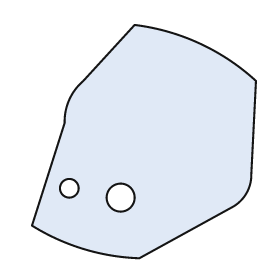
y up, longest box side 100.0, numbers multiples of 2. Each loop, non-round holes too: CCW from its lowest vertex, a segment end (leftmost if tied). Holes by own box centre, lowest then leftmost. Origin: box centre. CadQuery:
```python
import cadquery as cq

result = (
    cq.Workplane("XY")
    .moveTo(-2.0, -50.0)
    .lineTo(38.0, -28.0)
    .threePointArc((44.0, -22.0), (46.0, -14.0))
    .lineTo(48.0, 26.0)
    .threePointArc((24.0, 42.0), (-4.0, 50.0))
    .lineTo(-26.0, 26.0)
    .threePointArc((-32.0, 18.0), (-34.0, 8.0))
    .lineTo(-48.0, -36.0)
    .threePointArc((-26.0, -46.0), (-2.0, -50.0))
    .close()
    .moveTo(-10.0, -24.0)
    .circle(6.0)
    .moveTo(-32.0, -20.0)
    .circle(4.0)
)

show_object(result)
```